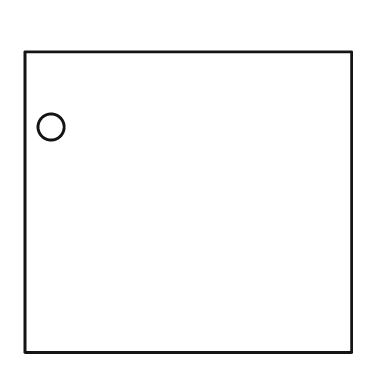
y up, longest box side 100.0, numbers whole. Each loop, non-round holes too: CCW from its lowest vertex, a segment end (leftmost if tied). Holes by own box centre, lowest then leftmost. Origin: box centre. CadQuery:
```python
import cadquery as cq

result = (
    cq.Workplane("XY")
    .moveTo(-50.0, -46.0)
    .lineTo(50.0, -46.0)
    .lineTo(50.0, 46.0)
    .lineTo(-50.0, 46.0)
    .close()
    .moveTo(-42.0, 23.0)
    .circle(4.0)
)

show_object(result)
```